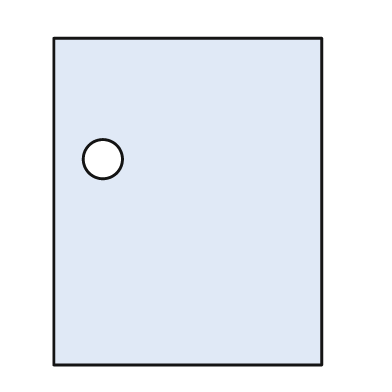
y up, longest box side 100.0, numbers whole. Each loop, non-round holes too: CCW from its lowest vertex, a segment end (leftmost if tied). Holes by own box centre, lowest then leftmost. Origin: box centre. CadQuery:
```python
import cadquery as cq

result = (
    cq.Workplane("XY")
    .moveTo(-41.0, -50.0)
    .lineTo(41.0, -50.0)
    .lineTo(41.0, 50.0)
    .lineTo(-41.0, 50.0)
    .close()
    .moveTo(-26.0, 13.0)
    .circle(6.0)
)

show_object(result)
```